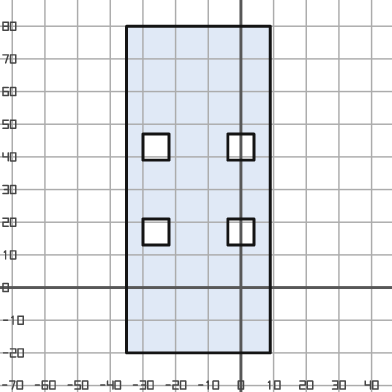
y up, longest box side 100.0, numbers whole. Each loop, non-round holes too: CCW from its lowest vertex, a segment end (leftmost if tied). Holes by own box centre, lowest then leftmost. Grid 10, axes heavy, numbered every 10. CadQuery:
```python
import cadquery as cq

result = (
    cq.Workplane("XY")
    .moveTo(-35.0, -20.0)
    .lineTo(9.0, -20.0)
    .lineTo(9.0, 80.0)
    .lineTo(-35.0, 80.0)
    .close()
    .moveTo(-30.0, 13.0)
    .lineTo(-22.0, 13.0)
    .lineTo(-22.0, 21.0)
    .lineTo(-30.0, 21.0)
    .close()
    .moveTo(-4.0, 13.0)
    .lineTo(4.0, 13.0)
    .lineTo(4.0, 21.0)
    .lineTo(-4.0, 21.0)
    .close()
    .moveTo(-30.0, 39.0)
    .lineTo(-22.0, 39.0)
    .lineTo(-22.0, 47.0)
    .lineTo(-30.0, 47.0)
    .close()
    .moveTo(-4.0, 39.0)
    .lineTo(4.0, 39.0)
    .lineTo(4.0, 47.0)
    .lineTo(-4.0, 47.0)
    .close()
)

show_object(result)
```